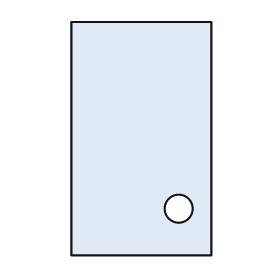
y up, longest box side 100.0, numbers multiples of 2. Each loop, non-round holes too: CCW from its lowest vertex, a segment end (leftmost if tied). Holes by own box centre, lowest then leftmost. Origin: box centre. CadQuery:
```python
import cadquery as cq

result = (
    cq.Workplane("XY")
    .moveTo(-30.0, -50.0)
    .lineTo(30.0, -50.0)
    .lineTo(30.0, 50.0)
    .lineTo(-30.0, 50.0)
    .close()
    .moveTo(16.0, -30.0)
    .circle(6.0)
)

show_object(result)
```